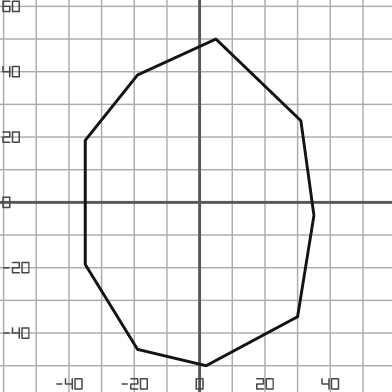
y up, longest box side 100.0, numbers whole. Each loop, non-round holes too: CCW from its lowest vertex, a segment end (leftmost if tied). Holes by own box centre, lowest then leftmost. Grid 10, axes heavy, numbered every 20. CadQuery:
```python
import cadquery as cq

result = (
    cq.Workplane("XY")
    .moveTo(2.0, -50.0)
    .lineTo(30.0, -35.0)
    .lineTo(35.0, -4.0)
    .lineTo(31.0, 25.0)
    .lineTo(5.0, 50.0)
    .lineTo(-19.0, 39.0)
    .lineTo(-35.0, 19.0)
    .lineTo(-35.0, -19.0)
    .lineTo(-19.0, -45.0)
    .close()
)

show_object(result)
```